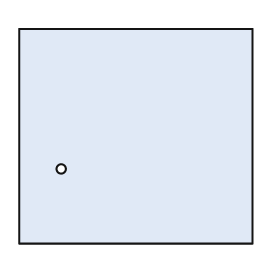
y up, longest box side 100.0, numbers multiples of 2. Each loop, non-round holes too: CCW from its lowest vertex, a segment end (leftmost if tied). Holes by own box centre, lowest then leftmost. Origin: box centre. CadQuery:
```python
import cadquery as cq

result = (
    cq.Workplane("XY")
    .moveTo(-50.0, -46.0)
    .lineTo(50.0, -46.0)
    .lineTo(50.0, 46.0)
    .lineTo(-50.0, 46.0)
    .close()
    .moveTo(-32.0, -14.0)
    .circle(2.0)
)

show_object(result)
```